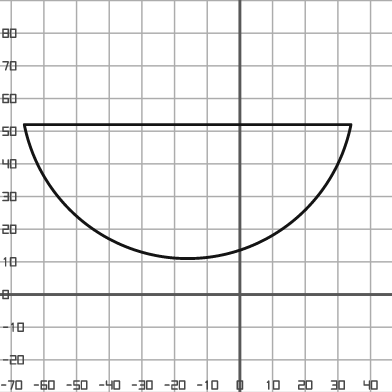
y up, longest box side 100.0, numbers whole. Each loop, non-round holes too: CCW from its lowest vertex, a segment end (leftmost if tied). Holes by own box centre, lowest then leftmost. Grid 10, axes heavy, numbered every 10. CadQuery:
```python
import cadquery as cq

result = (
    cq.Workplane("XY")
    .moveTo(-66.0, 52.0)
    .threePointArc((-16.0, 11.0), (34.0, 52.0))
    .close()
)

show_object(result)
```